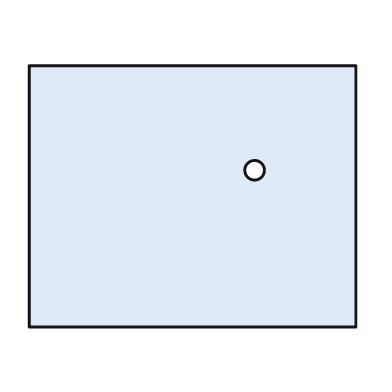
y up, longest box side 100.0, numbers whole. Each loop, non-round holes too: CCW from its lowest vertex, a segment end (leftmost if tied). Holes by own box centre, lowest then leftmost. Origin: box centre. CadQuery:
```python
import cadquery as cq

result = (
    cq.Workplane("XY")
    .moveTo(-50.0, -40.0)
    .lineTo(50.0, -40.0)
    .lineTo(50.0, 40.0)
    .lineTo(-50.0, 40.0)
    .close()
    .moveTo(19.0, 8.0)
    .circle(3.0)
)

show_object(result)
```